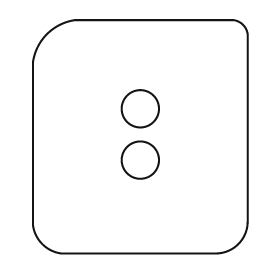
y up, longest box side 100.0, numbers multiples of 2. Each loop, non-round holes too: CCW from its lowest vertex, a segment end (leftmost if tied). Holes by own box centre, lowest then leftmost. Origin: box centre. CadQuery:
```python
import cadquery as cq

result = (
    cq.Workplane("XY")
    .moveTo(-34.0, -50.0)
    .lineTo(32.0, -50.0)
    .threePointArc((42.0, -46.0), (46.0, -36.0))
    .lineTo(46.0, 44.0)
    .threePointArc((44.0, 48.0), (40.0, 50.0))
    .lineTo(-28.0, 50.0)
    .threePointArc((-40.0, 44.0), (-46.0, 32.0))
    .lineTo(-46.0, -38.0)
    .threePointArc((-42.0, -46.0), (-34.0, -50.0))
    .close()
    .moveTo(0.0, -10.0)
    .circle(8.0)
    .moveTo(0.0, 12.0)
    .circle(8.0)
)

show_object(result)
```